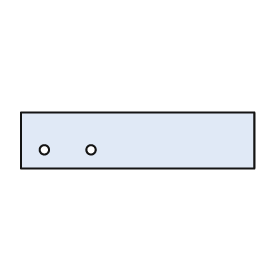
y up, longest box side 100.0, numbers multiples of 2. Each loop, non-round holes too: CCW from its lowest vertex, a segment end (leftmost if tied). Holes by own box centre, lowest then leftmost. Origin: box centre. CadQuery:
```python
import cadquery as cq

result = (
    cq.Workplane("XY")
    .moveTo(-50.0, -12.0)
    .lineTo(50.0, -12.0)
    .lineTo(50.0, 12.0)
    .lineTo(-50.0, 12.0)
    .close()
    .moveTo(-40.0, -4.0)
    .circle(2.0)
    .moveTo(-20.0, -4.0)
    .circle(2.0)
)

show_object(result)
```